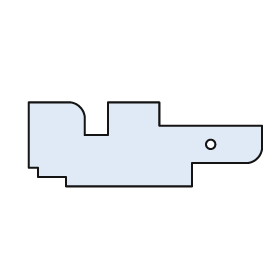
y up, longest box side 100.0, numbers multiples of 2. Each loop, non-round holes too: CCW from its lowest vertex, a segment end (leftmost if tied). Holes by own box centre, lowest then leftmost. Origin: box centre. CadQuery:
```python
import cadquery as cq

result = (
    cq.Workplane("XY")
    .moveTo(-34.0, -18.0)
    .lineTo(20.0, -18.0)
    .lineTo(20.0, -8.0)
    .lineTo(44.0, -8.0)
    .threePointArc((48.0, -6.0), (50.0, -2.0))
    .lineTo(50.0, 8.0)
    .lineTo(6.0, 8.0)
    .lineTo(6.0, 18.0)
    .lineTo(-16.0, 18.0)
    .lineTo(-16.0, 4.0)
    .lineTo(-26.0, 4.0)
    .lineTo(-26.0, 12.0)
    .threePointArc((-28.0, 16.0), (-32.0, 18.0))
    .lineTo(-50.0, 18.0)
    .lineTo(-50.0, -10.0)
    .lineTo(-46.0, -10.0)
    .lineTo(-46.0, -14.0)
    .lineTo(-34.0, -14.0)
    .close()
    .moveTo(28.0, 0.0)
    .circle(2.0)
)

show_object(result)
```